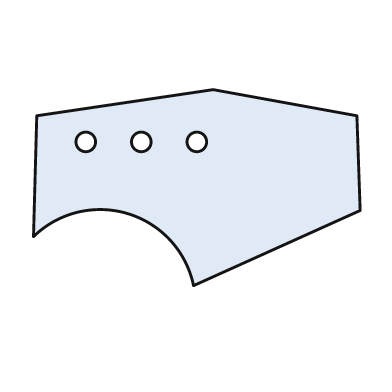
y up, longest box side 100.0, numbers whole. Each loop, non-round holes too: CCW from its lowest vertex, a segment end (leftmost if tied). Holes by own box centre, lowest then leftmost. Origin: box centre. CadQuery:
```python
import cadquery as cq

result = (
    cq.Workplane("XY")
    .moveTo(-1.0, -30.0)
    .lineTo(50.0, -7.0)
    .lineTo(49.0, 22.0)
    .lineTo(5.0, 30.0)
    .lineTo(-49.0, 22.0)
    .lineTo(-50.0, -15.0)
    .threePointArc((-21.0, -8.0), (-1.0, -30.0))
    .close()
    .moveTo(-34.0, 14.0)
    .circle(3.0)
    .moveTo(-17.0, 14.0)
    .circle(3.0)
    .moveTo(0.0, 14.0)
    .circle(3.0)
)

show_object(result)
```